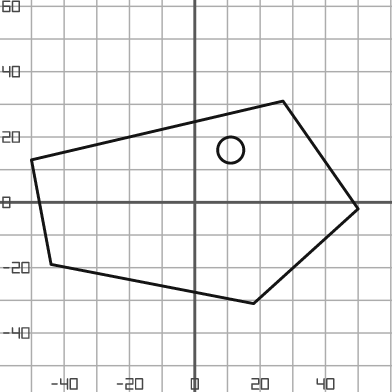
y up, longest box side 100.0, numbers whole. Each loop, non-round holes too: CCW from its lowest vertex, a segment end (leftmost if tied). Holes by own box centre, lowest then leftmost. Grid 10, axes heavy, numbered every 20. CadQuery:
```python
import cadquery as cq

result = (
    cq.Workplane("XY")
    .moveTo(18.0, -31.0)
    .lineTo(50.0, -2.0)
    .lineTo(27.0, 31.0)
    .lineTo(-50.0, 13.0)
    .lineTo(-44.0, -19.0)
    .close()
    .moveTo(11.0, 16.0)
    .circle(4.0)
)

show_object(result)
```